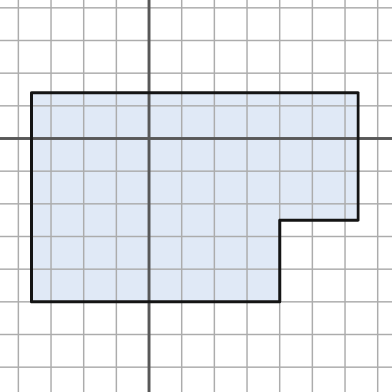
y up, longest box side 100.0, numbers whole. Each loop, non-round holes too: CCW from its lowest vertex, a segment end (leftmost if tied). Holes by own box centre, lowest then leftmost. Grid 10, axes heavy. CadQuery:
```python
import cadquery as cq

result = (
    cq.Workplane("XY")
    .moveTo(-36.0, -50.0)
    .lineTo(40.0, -50.0)
    .lineTo(40.0, -25.0)
    .lineTo(64.0, -25.0)
    .lineTo(64.0, 14.0)
    .lineTo(-36.0, 14.0)
    .close()
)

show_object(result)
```